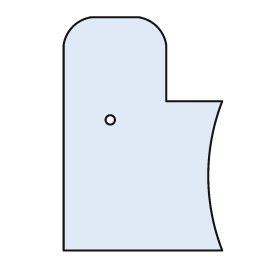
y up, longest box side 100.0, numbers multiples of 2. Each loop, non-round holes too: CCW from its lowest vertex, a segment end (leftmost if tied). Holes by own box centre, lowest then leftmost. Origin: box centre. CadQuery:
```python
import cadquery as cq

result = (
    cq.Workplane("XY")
    .moveTo(-34.0, -50.0)
    .lineTo(34.0, -50.0)
    .threePointArc((28.0, -18.0), (34.0, 14.0))
    .lineTo(10.0, 14.0)
    .lineTo(10.0, 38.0)
    .threePointArc((6.0, 46.0), (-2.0, 50.0))
    .lineTo(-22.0, 50.0)
    .threePointArc((-30.0, 46.0), (-34.0, 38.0))
    .close()
    .moveTo(-14.0, 6.0)
    .circle(2.0)
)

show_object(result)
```